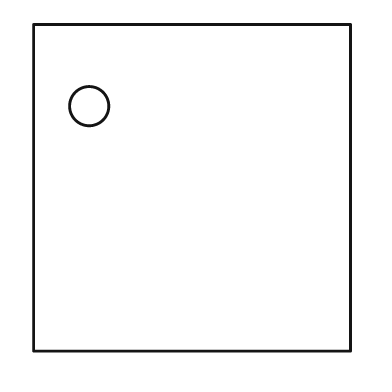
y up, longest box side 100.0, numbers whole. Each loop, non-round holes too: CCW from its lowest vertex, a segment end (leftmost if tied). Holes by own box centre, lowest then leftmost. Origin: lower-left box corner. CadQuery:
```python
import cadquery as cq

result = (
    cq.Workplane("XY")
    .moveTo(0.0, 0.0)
    .lineTo(97.0, 0.0)
    .lineTo(97.0, 100.0)
    .lineTo(0.0, 100.0)
    .close()
    .moveTo(17.0, 75.0)
    .circle(6.0)
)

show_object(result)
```